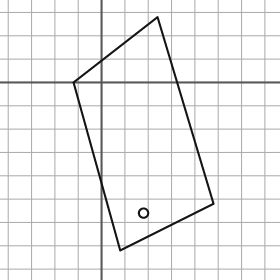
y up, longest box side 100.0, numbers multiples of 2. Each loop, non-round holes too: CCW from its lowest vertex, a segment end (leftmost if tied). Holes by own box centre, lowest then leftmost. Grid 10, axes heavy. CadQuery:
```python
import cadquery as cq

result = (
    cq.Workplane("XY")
    .moveTo(8.0, -72.0)
    .lineTo(48.0, -52.0)
    .lineTo(24.0, 28.0)
    .lineTo(-12.0, 0.0)
    .close()
    .moveTo(18.0, -56.0)
    .circle(2.0)
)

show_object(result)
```